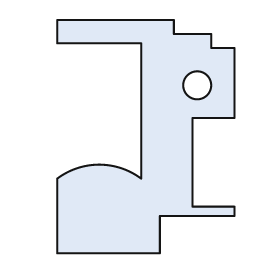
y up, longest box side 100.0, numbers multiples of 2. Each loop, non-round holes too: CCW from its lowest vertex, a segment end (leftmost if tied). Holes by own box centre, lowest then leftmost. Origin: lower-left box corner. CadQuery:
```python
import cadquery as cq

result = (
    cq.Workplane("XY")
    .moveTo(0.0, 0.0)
    .lineTo(44.0, 0.0)
    .lineTo(44.0, 16.0)
    .lineTo(76.0, 16.0)
    .lineTo(76.0, 20.0)
    .lineTo(58.0, 20.0)
    .lineTo(58.0, 58.0)
    .lineTo(76.0, 58.0)
    .lineTo(76.0, 88.0)
    .lineTo(66.0, 88.0)
    .lineTo(66.0, 94.0)
    .lineTo(50.0, 94.0)
    .lineTo(50.0, 100.0)
    .lineTo(0.0, 100.0)
    .lineTo(0.0, 90.0)
    .lineTo(36.0, 90.0)
    .lineTo(36.0, 32.0)
    .threePointArc((18.0, 38.0), (0.0, 32.0))
    .close()
    .moveTo(60.0, 72.0)
    .circle(6.0)
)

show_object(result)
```